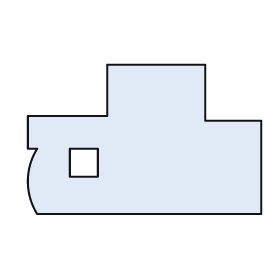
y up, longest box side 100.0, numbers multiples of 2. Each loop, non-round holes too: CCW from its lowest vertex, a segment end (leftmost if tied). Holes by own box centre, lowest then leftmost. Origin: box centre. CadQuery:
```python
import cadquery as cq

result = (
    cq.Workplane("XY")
    .moveTo(-46.0, -32.0)
    .lineTo(50.0, -32.0)
    .lineTo(50.0, 8.0)
    .lineTo(26.0, 8.0)
    .lineTo(26.0, 32.0)
    .lineTo(-16.0, 32.0)
    .lineTo(-16.0, 10.0)
    .lineTo(-50.0, 10.0)
    .lineTo(-50.0, -4.0)
    .lineTo(-46.0, -4.0)
    .threePointArc((-50.0, -18.0), (-46.0, -32.0))
    .close()
    .moveTo(-32.0, -16.0)
    .lineTo(-20.0, -16.0)
    .lineTo(-20.0, -4.0)
    .lineTo(-32.0, -4.0)
    .close()
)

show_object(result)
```